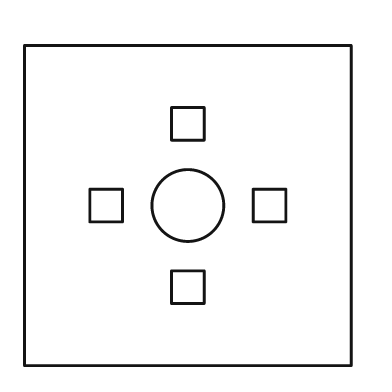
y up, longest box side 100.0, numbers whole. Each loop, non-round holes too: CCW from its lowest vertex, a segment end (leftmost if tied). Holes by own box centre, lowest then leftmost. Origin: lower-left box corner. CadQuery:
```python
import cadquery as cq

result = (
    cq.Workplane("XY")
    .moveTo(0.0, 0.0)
    .lineTo(100.0, 0.0)
    .lineTo(100.0, 98.0)
    .lineTo(0.0, 98.0)
    .close()
    .moveTo(45.0, 19.0)
    .lineTo(55.0, 19.0)
    .lineTo(55.0, 29.0)
    .lineTo(45.0, 29.0)
    .close()
    .moveTo(20.0, 44.0)
    .lineTo(30.0, 44.0)
    .lineTo(30.0, 54.0)
    .lineTo(20.0, 54.0)
    .close()
    .moveTo(50.0, 49.0)
    .circle(11.0)
    .moveTo(70.0, 44.0)
    .lineTo(80.0, 44.0)
    .lineTo(80.0, 54.0)
    .lineTo(70.0, 54.0)
    .close()
    .moveTo(45.0, 69.0)
    .lineTo(55.0, 69.0)
    .lineTo(55.0, 79.0)
    .lineTo(45.0, 79.0)
    .close()
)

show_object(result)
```